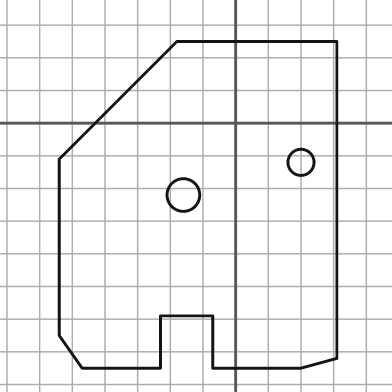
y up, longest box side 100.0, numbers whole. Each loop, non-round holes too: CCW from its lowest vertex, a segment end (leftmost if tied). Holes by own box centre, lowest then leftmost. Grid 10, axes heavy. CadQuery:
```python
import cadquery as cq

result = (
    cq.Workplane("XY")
    .moveTo(-47.0, -75.0)
    .lineTo(-23.0, -75.0)
    .lineTo(-23.0, -59.0)
    .lineTo(-7.0, -59.0)
    .lineTo(-7.0, -75.0)
    .lineTo(20.0, -75.0)
    .lineTo(31.0, -72.0)
    .lineTo(31.0, 25.0)
    .lineTo(-18.0, 25.0)
    .lineTo(-54.0, -11.0)
    .lineTo(-54.0, -65.0)
    .close()
    .moveTo(-16.0, -22.0)
    .circle(5.0)
    .moveTo(20.0, -12.0)
    .circle(4.0)
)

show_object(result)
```